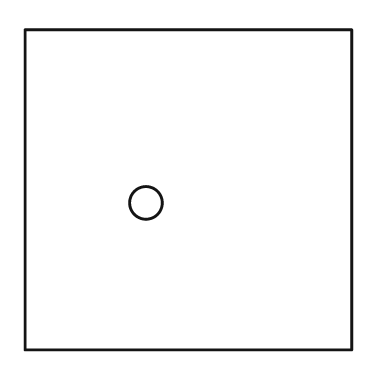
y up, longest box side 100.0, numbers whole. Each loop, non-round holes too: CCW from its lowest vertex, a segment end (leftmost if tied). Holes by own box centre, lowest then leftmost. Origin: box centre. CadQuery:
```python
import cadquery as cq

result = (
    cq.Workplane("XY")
    .moveTo(-50.0, -49.0)
    .lineTo(50.0, -49.0)
    .lineTo(50.0, 49.0)
    .lineTo(-50.0, 49.0)
    .close()
    .moveTo(-13.0, -4.0)
    .circle(5.0)
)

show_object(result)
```